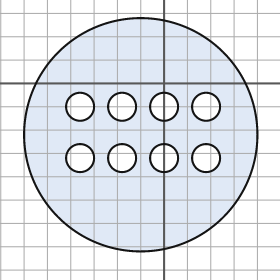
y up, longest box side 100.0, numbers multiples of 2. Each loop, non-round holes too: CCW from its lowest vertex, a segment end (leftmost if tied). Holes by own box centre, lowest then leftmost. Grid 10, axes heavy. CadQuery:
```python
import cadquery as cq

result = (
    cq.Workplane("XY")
    .moveTo(-10.0, -22.0)
    .circle(50.0)
    .moveTo(-36.0, -32.0)
    .circle(6.0)
    .moveTo(-18.0, -32.0)
    .circle(6.0)
    .moveTo(0.0, -32.0)
    .circle(6.0)
    .moveTo(18.0, -32.0)
    .circle(6.0)
    .moveTo(-36.0, -10.0)
    .circle(6.0)
    .moveTo(-18.0, -10.0)
    .circle(6.0)
    .moveTo(0.0, -10.0)
    .circle(6.0)
    .moveTo(18.0, -10.0)
    .circle(6.0)
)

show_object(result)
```